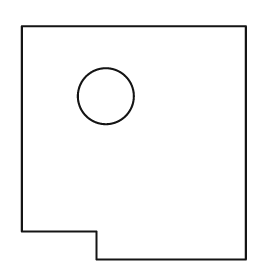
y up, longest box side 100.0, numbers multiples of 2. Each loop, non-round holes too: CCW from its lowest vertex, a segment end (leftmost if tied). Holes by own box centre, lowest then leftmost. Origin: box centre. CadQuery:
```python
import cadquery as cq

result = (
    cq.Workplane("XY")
    .moveTo(-16.0, -50.0)
    .lineTo(48.0, -50.0)
    .lineTo(48.0, 50.0)
    .lineTo(-48.0, 50.0)
    .lineTo(-48.0, -38.0)
    .lineTo(-16.0, -38.0)
    .close()
    .moveTo(-12.0, 20.0)
    .circle(12.0)
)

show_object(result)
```